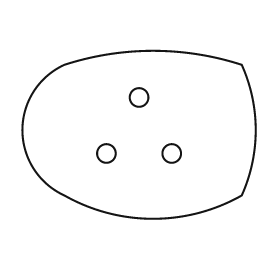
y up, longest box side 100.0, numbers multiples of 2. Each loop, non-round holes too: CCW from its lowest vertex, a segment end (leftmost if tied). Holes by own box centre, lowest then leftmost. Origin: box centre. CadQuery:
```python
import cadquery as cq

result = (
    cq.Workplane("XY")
    .moveTo(-32.0, -26.0)
    .threePointArc((6.0, -36.0), (44.0, -26.0))
    .threePointArc((50.0, 2.0), (44.0, 30.0))
    .threePointArc((6.0, 36.0), (-32.0, 30.0))
    .threePointArc((-50.0, 2.0), (-32.0, -26.0))
    .close()
    .moveTo(-14.0, -8.0)
    .circle(4.0)
    .moveTo(14.0, -8.0)
    .circle(4.0)
    .moveTo(0.0, 16.0)
    .circle(4.0)
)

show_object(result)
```